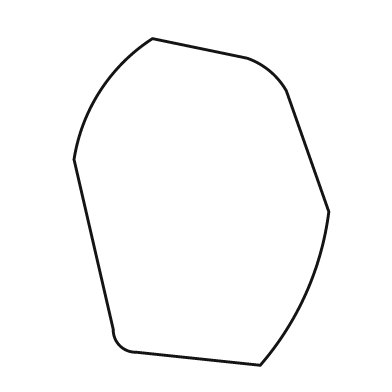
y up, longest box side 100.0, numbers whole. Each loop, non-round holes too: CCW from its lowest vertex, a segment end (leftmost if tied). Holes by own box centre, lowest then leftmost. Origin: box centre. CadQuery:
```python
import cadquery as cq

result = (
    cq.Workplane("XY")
    .moveTo(18.0, -50.0)
    .threePointArc((32.0, -28.0), (39.0, -3.0))
    .lineTo(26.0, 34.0)
    .threePointArc((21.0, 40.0), (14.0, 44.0))
    .lineTo(-15.0, 50.0)
    .threePointArc((-31.0, 34.0), (-39.0, 13.0))
    .lineTo(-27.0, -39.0)
    .threePointArc((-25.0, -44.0), (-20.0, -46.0))
    .close()
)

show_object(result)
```